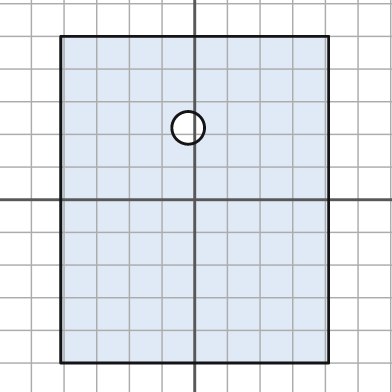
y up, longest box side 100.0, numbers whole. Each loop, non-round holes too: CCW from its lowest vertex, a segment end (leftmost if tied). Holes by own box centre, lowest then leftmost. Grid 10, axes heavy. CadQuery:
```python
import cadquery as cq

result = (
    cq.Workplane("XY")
    .moveTo(-41.0, -50.0)
    .lineTo(41.0, -50.0)
    .lineTo(41.0, 50.0)
    .lineTo(-41.0, 50.0)
    .close()
    .moveTo(-2.0, 22.0)
    .circle(5.0)
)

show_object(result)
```